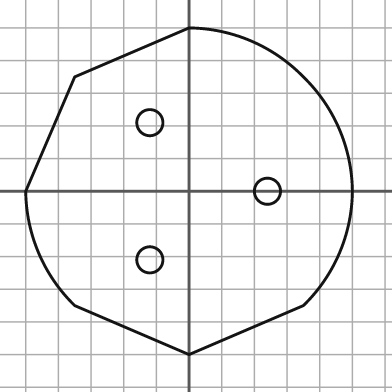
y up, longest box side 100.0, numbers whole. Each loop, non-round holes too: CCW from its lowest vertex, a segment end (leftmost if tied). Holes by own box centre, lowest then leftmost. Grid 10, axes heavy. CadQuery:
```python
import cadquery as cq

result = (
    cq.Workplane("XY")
    .moveTo(0.0, -50.0)
    .lineTo(35.0, -35.0)
    .threePointArc((46.0, -19.0), (50.0, 0.0))
    .threePointArc((46.0, 19.0), (35.0, 35.0))
    .threePointArc((19.0, 46.0), (0.0, 50.0))
    .lineTo(-35.0, 35.0)
    .lineTo(-50.0, 0.0)
    .threePointArc((-46.0, -19.0), (-35.0, -35.0))
    .close()
    .moveTo(-12.0, -21.0)
    .circle(4.0)
    .moveTo(24.0, 0.0)
    .circle(4.0)
    .moveTo(-12.0, 21.0)
    .circle(4.0)
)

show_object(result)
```